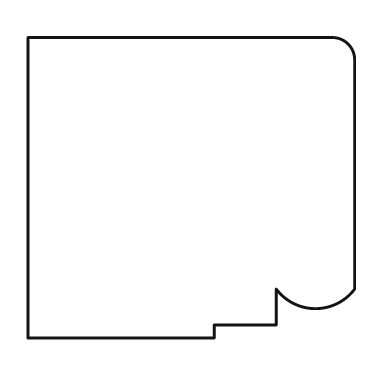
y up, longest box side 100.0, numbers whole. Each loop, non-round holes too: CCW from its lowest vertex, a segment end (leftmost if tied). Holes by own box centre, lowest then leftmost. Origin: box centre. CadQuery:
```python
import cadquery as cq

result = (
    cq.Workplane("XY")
    .moveTo(-50.0, -46.0)
    .lineTo(7.0, -46.0)
    .lineTo(7.0, -42.0)
    .lineTo(26.0, -42.0)
    .lineTo(26.0, -31.0)
    .threePointArc((38.0, -37.0), (50.0, -31.0))
    .lineTo(50.0, 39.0)
    .threePointArc((48.0, 44.0), (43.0, 46.0))
    .lineTo(-50.0, 46.0)
    .close()
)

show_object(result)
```